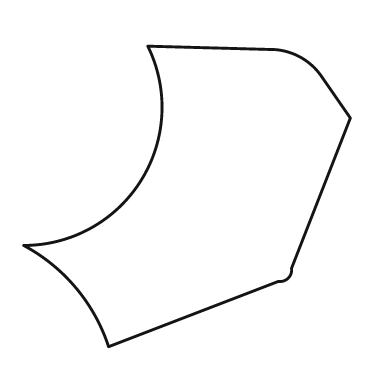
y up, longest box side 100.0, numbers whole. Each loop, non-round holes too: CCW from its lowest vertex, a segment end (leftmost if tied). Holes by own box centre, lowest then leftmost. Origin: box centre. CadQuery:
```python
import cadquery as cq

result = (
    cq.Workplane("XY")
    .moveTo(-24.0, -46.0)
    .lineTo(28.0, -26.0)
    .threePointArc((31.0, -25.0), (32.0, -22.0))
    .lineTo(50.0, 24.0)
    .lineTo(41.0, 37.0)
    .threePointArc((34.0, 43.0), (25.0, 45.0))
    .lineTo(-12.0, 46.0)
    .threePointArc((-14.0, 5.0), (-50.0, -15.0))
    .threePointArc((-34.0, -28.0), (-24.0, -46.0))
    .close()
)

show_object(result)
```